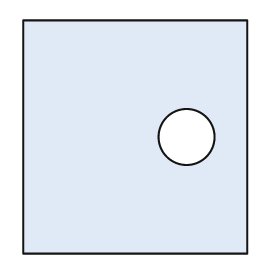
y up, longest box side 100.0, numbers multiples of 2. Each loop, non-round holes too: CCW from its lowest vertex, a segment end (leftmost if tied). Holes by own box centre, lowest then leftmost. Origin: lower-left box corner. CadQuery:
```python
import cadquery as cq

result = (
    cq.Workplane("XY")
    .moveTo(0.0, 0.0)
    .lineTo(96.0, 0.0)
    .lineTo(96.0, 100.0)
    .lineTo(0.0, 100.0)
    .close()
    .moveTo(70.0, 50.0)
    .circle(12.0)
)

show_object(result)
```